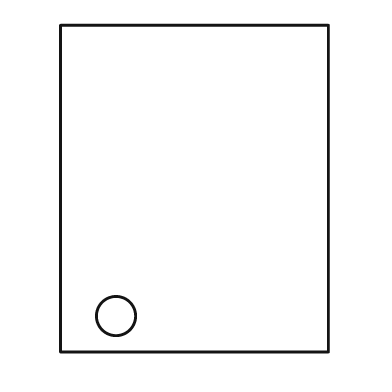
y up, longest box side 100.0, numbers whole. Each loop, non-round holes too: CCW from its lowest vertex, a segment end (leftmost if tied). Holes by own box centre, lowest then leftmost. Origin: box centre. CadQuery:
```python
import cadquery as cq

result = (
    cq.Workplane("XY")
    .moveTo(-41.0, -50.0)
    .lineTo(41.0, -50.0)
    .lineTo(41.0, 50.0)
    .lineTo(-41.0, 50.0)
    .close()
    .moveTo(-24.0, -39.0)
    .circle(6.0)
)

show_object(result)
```